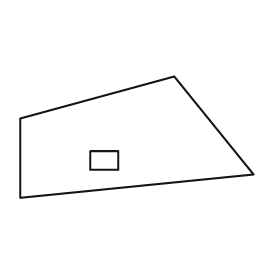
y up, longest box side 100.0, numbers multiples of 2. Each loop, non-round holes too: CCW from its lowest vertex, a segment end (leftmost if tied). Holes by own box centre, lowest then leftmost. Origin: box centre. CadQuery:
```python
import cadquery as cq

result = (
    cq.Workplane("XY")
    .moveTo(-50.0, -26.0)
    .lineTo(50.0, -16.0)
    .lineTo(16.0, 26.0)
    .lineTo(-50.0, 8.0)
    .close()
    .moveTo(-20.0, -14.0)
    .lineTo(-8.0, -14.0)
    .lineTo(-8.0, -6.0)
    .lineTo(-20.0, -6.0)
    .close()
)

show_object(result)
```